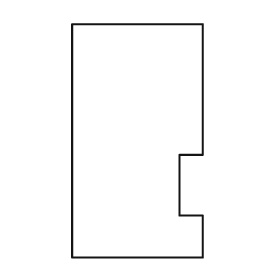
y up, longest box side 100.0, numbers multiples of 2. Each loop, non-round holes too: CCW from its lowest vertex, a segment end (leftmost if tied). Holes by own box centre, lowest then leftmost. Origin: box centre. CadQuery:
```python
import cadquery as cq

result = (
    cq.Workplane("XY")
    .moveTo(-28.0, -50.0)
    .lineTo(28.0, -50.0)
    .lineTo(28.0, -32.0)
    .lineTo(18.0, -32.0)
    .lineTo(18.0, -6.0)
    .lineTo(28.0, -6.0)
    .lineTo(28.0, 50.0)
    .lineTo(-28.0, 50.0)
    .close()
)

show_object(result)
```